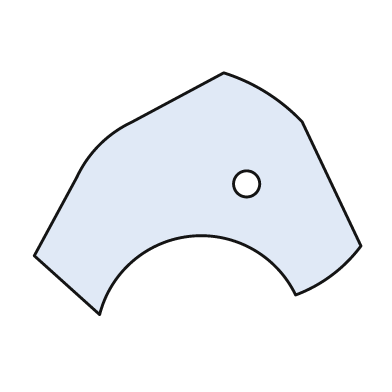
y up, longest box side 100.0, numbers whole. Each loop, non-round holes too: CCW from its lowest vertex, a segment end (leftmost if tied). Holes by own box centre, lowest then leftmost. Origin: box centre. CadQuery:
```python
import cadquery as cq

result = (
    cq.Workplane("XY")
    .moveTo(-30.0, -37.0)
    .threePointArc((-2.0, -13.0), (30.0, -31.0))
    .threePointArc((41.0, -25.0), (50.0, -16.0))
    .lineTo(32.0, 22.0)
    .threePointArc((21.0, 31.0), (8.0, 37.0))
    .lineTo(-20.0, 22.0)
    .threePointArc((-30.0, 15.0), (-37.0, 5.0))
    .lineTo(-50.0, -19.0)
    .close()
    .moveTo(15.0, 3.0)
    .circle(4.0)
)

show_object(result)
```